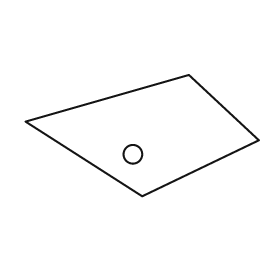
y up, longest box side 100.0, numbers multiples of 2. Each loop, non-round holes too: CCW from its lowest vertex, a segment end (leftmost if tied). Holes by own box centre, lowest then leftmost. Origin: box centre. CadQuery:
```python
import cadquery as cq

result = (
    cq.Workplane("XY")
    .moveTo(0.0, -26.0)
    .lineTo(50.0, -2.0)
    .lineTo(20.0, 26.0)
    .lineTo(-50.0, 6.0)
    .close()
    .moveTo(-4.0, -8.0)
    .circle(4.0)
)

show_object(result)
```